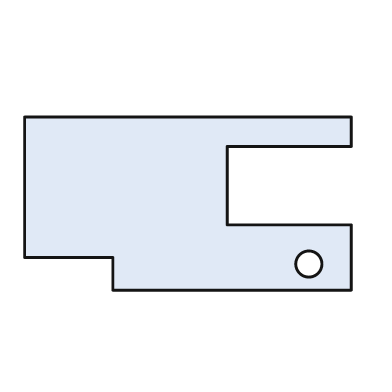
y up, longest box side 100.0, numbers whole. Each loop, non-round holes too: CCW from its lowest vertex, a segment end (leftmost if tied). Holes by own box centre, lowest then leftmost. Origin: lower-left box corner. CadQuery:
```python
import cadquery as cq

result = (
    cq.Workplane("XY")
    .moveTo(27.0, 0.0)
    .lineTo(100.0, 0.0)
    .lineTo(100.0, 20.0)
    .lineTo(62.0, 20.0)
    .lineTo(62.0, 44.0)
    .lineTo(100.0, 44.0)
    .lineTo(100.0, 53.0)
    .lineTo(0.0, 53.0)
    .lineTo(0.0, 10.0)
    .lineTo(27.0, 10.0)
    .close()
    .moveTo(87.0, 8.0)
    .circle(4.0)
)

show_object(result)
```